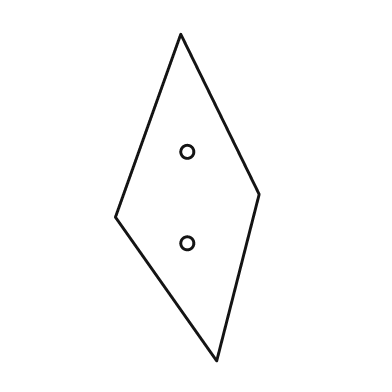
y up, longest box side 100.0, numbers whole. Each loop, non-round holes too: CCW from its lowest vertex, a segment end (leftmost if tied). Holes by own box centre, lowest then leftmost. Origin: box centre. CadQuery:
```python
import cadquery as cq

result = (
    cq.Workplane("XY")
    .moveTo(9.0, -50.0)
    .lineTo(22.0, 1.0)
    .lineTo(-2.0, 50.0)
    .lineTo(-22.0, -6.0)
    .close()
    .moveTo(0.0, -14.0)
    .circle(2.0)
    .moveTo(0.0, 14.0)
    .circle(2.0)
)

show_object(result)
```